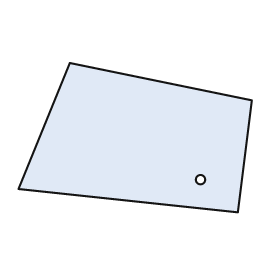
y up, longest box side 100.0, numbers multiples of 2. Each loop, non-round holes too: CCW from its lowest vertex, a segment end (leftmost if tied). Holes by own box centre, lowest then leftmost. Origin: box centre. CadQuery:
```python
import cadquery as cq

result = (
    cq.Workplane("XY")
    .moveTo(44.0, -32.0)
    .lineTo(50.0, 16.0)
    .lineTo(-28.0, 32.0)
    .lineTo(-50.0, -22.0)
    .close()
    .moveTo(28.0, -18.0)
    .circle(2.0)
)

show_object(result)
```